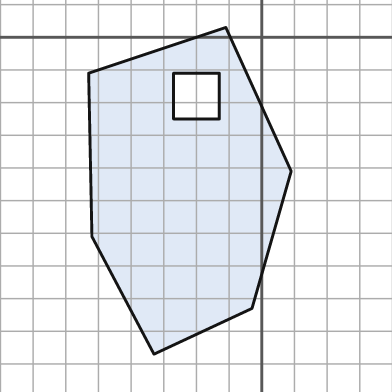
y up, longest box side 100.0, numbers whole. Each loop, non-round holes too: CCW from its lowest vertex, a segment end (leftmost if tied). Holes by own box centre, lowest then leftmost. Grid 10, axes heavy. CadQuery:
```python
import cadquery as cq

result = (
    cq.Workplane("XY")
    .moveTo(-33.0, -97.0)
    .lineTo(-3.0, -83.0)
    .lineTo(9.0, -41.0)
    .lineTo(-11.0, 3.0)
    .lineTo(-53.0, -11.0)
    .lineTo(-52.0, -61.0)
    .close()
    .moveTo(-27.0, -25.0)
    .lineTo(-13.0, -25.0)
    .lineTo(-13.0, -11.0)
    .lineTo(-27.0, -11.0)
    .close()
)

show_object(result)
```